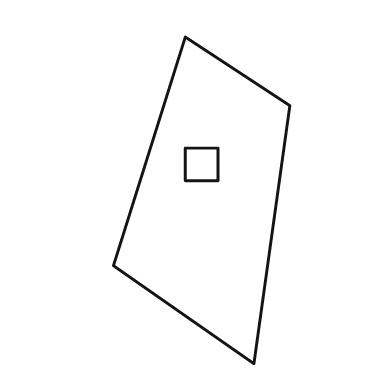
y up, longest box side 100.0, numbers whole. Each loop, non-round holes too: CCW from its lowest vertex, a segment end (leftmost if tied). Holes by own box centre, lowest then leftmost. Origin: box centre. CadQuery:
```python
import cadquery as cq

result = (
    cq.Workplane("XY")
    .moveTo(16.0, -50.0)
    .lineTo(27.0, 29.0)
    .lineTo(-5.0, 50.0)
    .lineTo(-27.0, -20.0)
    .close()
    .moveTo(-5.0, 6.0)
    .lineTo(5.0, 6.0)
    .lineTo(5.0, 16.0)
    .lineTo(-5.0, 16.0)
    .close()
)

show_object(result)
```